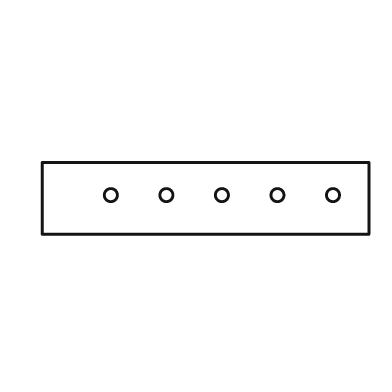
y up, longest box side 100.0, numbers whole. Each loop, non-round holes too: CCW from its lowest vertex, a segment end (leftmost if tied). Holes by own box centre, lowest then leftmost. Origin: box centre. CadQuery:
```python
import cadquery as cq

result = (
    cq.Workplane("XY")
    .moveTo(-50.0, -11.0)
    .lineTo(50.0, -11.0)
    .lineTo(50.0, 11.0)
    .lineTo(-50.0, 11.0)
    .close()
    .moveTo(-29.0, 1.0)
    .circle(2.0)
    .moveTo(-12.0, 1.0)
    .circle(2.0)
    .moveTo(5.0, 1.0)
    .circle(2.0)
    .moveTo(22.0, 1.0)
    .circle(2.0)
    .moveTo(39.0, 1.0)
    .circle(2.0)
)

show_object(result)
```